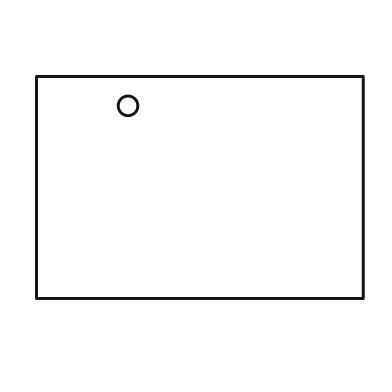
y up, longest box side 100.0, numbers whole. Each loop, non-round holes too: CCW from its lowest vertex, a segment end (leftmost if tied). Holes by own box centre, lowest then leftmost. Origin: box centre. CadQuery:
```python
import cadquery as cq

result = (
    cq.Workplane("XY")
    .moveTo(-50.0, -34.0)
    .lineTo(50.0, -34.0)
    .lineTo(50.0, 34.0)
    .lineTo(-50.0, 34.0)
    .close()
    .moveTo(-22.0, 25.0)
    .circle(3.0)
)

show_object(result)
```